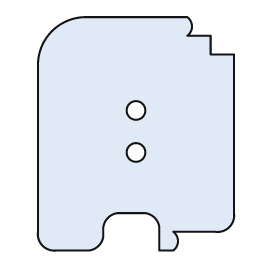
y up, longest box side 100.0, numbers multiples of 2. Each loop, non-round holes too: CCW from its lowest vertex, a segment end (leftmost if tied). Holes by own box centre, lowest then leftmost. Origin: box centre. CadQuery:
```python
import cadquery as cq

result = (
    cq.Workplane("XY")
    .moveTo(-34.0, -50.0)
    .lineTo(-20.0, -50.0)
    .threePointArc((-16.0, -48.0), (-14.0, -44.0))
    .lineTo(-14.0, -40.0)
    .threePointArc((-12.0, -36.0), (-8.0, -34.0))
    .lineTo(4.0, -34.0)
    .threePointArc((8.0, -36.0), (10.0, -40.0))
    .lineTo(10.0, -50.0)
    .lineTo(16.0, -50.0)
    .threePointArc((18.0, -46.0), (16.0, -42.0))
    .lineTo(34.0, -42.0)
    .threePointArc((40.0, -40.0), (42.0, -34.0))
    .lineTo(42.0, 34.0)
    .lineTo(32.0, 34.0)
    .lineTo(32.0, 42.0)
    .lineTo(22.0, 42.0)
    .threePointArc((24.0, 46.0), (22.0, 50.0))
    .lineTo(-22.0, 50.0)
    .threePointArc((-36.0, 44.0), (-42.0, 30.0))
    .lineTo(-42.0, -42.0)
    .threePointArc((-40.0, -48.0), (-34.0, -50.0))
    .close()
    .moveTo(0.0, -8.0)
    .circle(4.0)
    .moveTo(0.0, 10.0)
    .circle(4.0)
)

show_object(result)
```